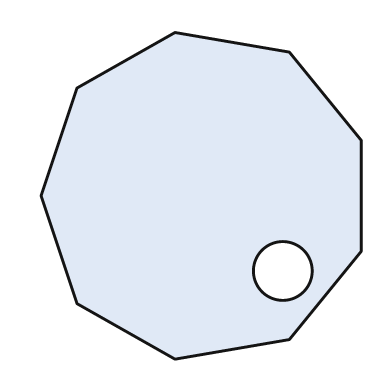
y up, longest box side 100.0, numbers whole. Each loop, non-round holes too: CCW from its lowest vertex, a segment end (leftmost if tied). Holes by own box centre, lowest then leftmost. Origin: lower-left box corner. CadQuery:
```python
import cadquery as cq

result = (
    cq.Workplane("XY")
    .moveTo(41.0, 0.0)
    .lineTo(76.0, 6.0)
    .lineTo(98.0, 33.0)
    .lineTo(98.0, 67.0)
    .lineTo(76.0, 94.0)
    .lineTo(41.0, 100.0)
    .lineTo(11.0, 83.0)
    .lineTo(0.0, 50.0)
    .lineTo(11.0, 17.0)
    .close()
    .moveTo(74.0, 27.0)
    .circle(9.0)
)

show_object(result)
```